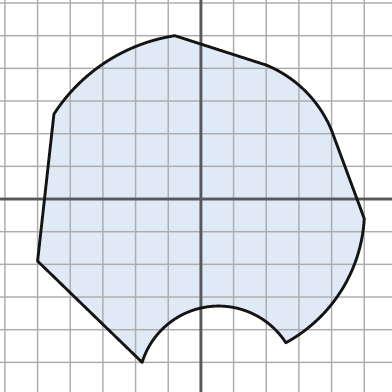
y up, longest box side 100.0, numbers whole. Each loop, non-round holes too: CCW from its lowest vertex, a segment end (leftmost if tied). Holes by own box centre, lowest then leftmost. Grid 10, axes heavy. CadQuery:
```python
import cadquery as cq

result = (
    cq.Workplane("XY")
    .moveTo(-18.0, -50.0)
    .threePointArc((2.0, -33.0), (26.0, -44.0))
    .threePointArc((43.0, -28.0), (50.0, -6.0))
    .lineTo(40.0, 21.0)
    .threePointArc((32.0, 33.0), (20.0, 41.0))
    .lineTo(-8.0, 50.0)
    .threePointArc((-29.0, 42.0), (-45.0, 26.0))
    .lineTo(-50.0, -19.0)
    .close()
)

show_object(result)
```